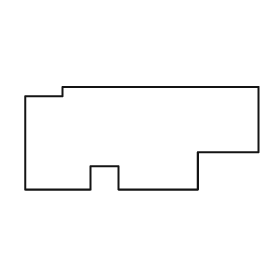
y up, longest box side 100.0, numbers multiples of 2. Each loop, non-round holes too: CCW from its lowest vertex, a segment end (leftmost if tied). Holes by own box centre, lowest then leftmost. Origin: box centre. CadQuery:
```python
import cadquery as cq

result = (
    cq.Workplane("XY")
    .moveTo(-50.0, -22.0)
    .lineTo(-22.0, -22.0)
    .lineTo(-22.0, -12.0)
    .lineTo(-10.0, -12.0)
    .lineTo(-10.0, -22.0)
    .lineTo(24.0, -22.0)
    .lineTo(24.0, -6.0)
    .lineTo(50.0, -6.0)
    .lineTo(50.0, 22.0)
    .lineTo(-34.0, 22.0)
    .lineTo(-34.0, 18.0)
    .lineTo(-50.0, 18.0)
    .close()
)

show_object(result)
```